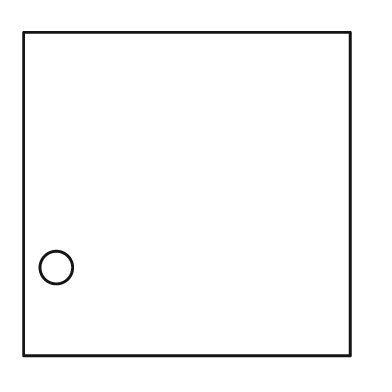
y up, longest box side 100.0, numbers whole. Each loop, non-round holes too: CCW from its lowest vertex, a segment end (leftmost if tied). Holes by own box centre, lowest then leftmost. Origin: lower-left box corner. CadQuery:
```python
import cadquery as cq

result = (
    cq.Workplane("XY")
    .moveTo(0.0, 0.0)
    .lineTo(100.0, 0.0)
    .lineTo(100.0, 99.0)
    .lineTo(0.0, 99.0)
    .close()
    .moveTo(10.0, 27.0)
    .circle(5.0)
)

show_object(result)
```